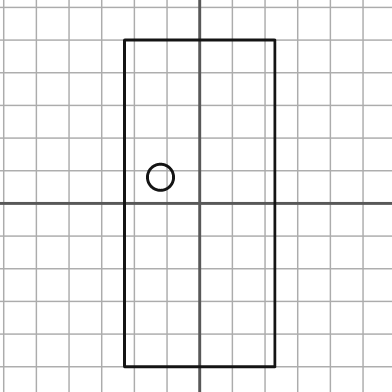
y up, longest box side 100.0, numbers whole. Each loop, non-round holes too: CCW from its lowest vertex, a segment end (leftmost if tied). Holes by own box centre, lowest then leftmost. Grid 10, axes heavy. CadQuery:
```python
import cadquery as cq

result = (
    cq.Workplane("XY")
    .moveTo(-23.0, -50.0)
    .lineTo(23.0, -50.0)
    .lineTo(23.0, 50.0)
    .lineTo(-23.0, 50.0)
    .close()
    .moveTo(-12.0, 8.0)
    .circle(4.0)
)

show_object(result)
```